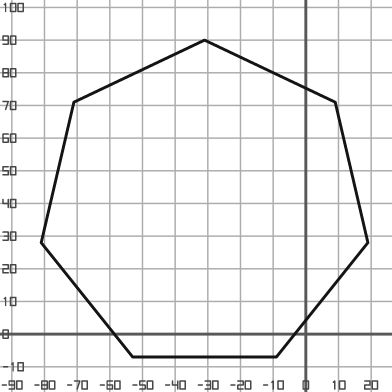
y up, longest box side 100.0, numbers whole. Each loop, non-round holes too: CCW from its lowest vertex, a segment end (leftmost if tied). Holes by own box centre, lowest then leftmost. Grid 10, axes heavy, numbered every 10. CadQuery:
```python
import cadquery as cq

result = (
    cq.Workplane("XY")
    .moveTo(-53.0, -7.0)
    .lineTo(-9.0, -7.0)
    .lineTo(19.0, 28.0)
    .lineTo(9.0, 71.0)
    .lineTo(-31.0, 90.0)
    .lineTo(-71.0, 71.0)
    .lineTo(-81.0, 28.0)
    .close()
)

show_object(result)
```